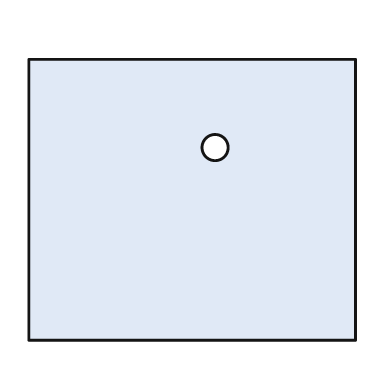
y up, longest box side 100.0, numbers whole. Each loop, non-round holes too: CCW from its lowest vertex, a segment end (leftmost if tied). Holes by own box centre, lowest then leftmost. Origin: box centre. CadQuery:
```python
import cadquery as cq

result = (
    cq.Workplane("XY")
    .moveTo(-50.0, -43.0)
    .lineTo(50.0, -43.0)
    .lineTo(50.0, 43.0)
    .lineTo(-50.0, 43.0)
    .close()
    .moveTo(7.0, 16.0)
    .circle(4.0)
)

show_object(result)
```